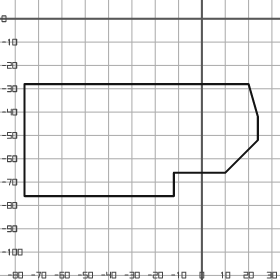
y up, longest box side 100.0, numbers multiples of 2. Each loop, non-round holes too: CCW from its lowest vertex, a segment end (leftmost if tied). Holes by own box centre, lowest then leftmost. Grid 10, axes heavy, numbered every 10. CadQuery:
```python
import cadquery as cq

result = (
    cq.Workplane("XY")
    .moveTo(-76.0, -76.0)
    .lineTo(-12.0, -76.0)
    .lineTo(-12.0, -66.0)
    .lineTo(10.0, -66.0)
    .lineTo(24.0, -52.0)
    .lineTo(24.0, -42.0)
    .lineTo(20.0, -28.0)
    .lineTo(-76.0, -28.0)
    .close()
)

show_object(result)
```